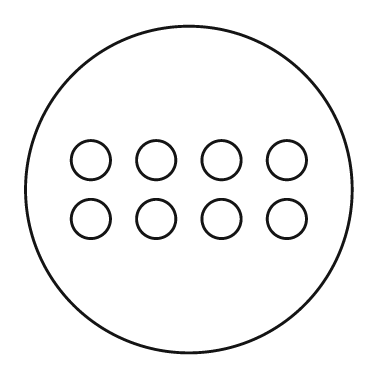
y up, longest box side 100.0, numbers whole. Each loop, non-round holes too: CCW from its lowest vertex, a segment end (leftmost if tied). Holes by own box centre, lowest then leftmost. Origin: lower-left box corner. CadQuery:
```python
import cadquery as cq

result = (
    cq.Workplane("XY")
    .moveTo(50.0, 50.0)
    .circle(50.0)
    .moveTo(20.0, 41.0)
    .circle(6.0)
    .moveTo(40.0, 41.0)
    .circle(6.0)
    .moveTo(60.0, 41.0)
    .circle(6.0)
    .moveTo(80.0, 41.0)
    .circle(6.0)
    .moveTo(20.0, 59.0)
    .circle(6.0)
    .moveTo(40.0, 59.0)
    .circle(6.0)
    .moveTo(60.0, 59.0)
    .circle(6.0)
    .moveTo(80.0, 59.0)
    .circle(6.0)
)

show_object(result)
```